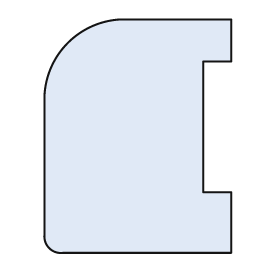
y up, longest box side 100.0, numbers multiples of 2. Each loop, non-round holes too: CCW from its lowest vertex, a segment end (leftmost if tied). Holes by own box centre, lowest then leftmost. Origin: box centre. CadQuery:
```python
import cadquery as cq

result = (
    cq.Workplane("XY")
    .moveTo(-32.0, -50.0)
    .lineTo(40.0, -50.0)
    .lineTo(40.0, -24.0)
    .lineTo(28.0, -24.0)
    .lineTo(28.0, 32.0)
    .lineTo(40.0, 32.0)
    .lineTo(40.0, 50.0)
    .lineTo(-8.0, 50.0)
    .threePointArc((-30.0, 40.0), (-40.0, 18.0))
    .lineTo(-40.0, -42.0)
    .threePointArc((-38.0, -48.0), (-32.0, -50.0))
    .close()
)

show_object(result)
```